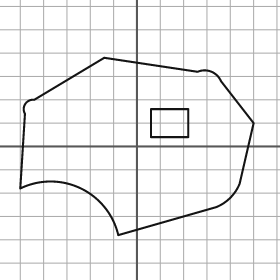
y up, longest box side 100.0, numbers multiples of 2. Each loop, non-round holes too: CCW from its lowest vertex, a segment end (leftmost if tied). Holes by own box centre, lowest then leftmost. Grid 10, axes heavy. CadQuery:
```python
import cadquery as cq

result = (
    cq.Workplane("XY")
    .moveTo(-8.0, -38.0)
    .lineTo(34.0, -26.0)
    .threePointArc((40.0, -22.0), (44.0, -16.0))
    .lineTo(50.0, 10.0)
    .lineTo(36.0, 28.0)
    .threePointArc((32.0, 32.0), (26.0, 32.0))
    .lineTo(-14.0, 38.0)
    .lineTo(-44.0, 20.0)
    .threePointArc((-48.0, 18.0), (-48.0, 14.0))
    .lineTo(-50.0, -18.0)
    .threePointArc((-24.0, -18.0), (-8.0, -38.0))
    .close()
    .moveTo(6.0, 4.0)
    .lineTo(22.0, 4.0)
    .lineTo(22.0, 16.0)
    .lineTo(6.0, 16.0)
    .close()
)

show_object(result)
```